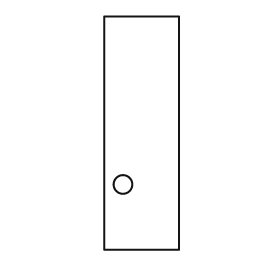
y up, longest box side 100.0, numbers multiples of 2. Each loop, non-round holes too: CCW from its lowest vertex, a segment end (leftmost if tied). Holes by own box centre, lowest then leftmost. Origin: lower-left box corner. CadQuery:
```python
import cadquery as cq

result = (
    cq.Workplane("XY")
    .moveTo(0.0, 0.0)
    .lineTo(32.0, 0.0)
    .lineTo(32.0, 100.0)
    .lineTo(0.0, 100.0)
    .close()
    .moveTo(8.0, 28.0)
    .circle(4.0)
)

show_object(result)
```